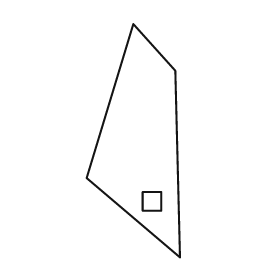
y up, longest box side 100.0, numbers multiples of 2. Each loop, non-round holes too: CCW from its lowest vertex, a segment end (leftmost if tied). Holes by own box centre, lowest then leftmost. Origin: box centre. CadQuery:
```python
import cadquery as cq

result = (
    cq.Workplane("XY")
    .moveTo(20.0, -50.0)
    .lineTo(18.0, 30.0)
    .lineTo(0.0, 50.0)
    .lineTo(-20.0, -16.0)
    .close()
    .moveTo(4.0, -30.0)
    .lineTo(12.0, -30.0)
    .lineTo(12.0, -22.0)
    .lineTo(4.0, -22.0)
    .close()
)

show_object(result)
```